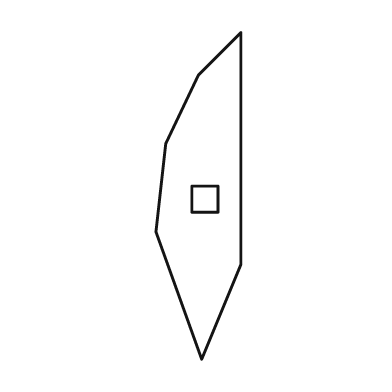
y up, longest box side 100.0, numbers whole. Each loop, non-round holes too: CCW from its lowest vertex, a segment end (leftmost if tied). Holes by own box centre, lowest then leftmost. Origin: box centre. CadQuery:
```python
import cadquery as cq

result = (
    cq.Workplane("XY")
    .moveTo(1.0, -50.0)
    .lineTo(13.0, -21.0)
    .lineTo(13.0, 50.0)
    .lineTo(0.0, 37.0)
    .lineTo(-10.0, 16.0)
    .lineTo(-13.0, -11.0)
    .close()
    .moveTo(-2.0, -5.0)
    .lineTo(6.0, -5.0)
    .lineTo(6.0, 3.0)
    .lineTo(-2.0, 3.0)
    .close()
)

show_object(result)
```